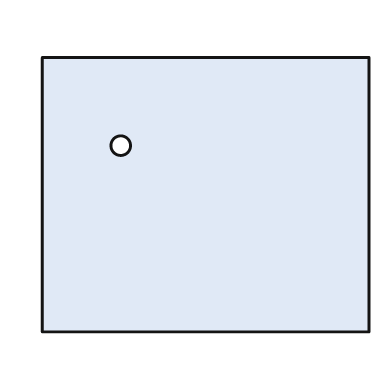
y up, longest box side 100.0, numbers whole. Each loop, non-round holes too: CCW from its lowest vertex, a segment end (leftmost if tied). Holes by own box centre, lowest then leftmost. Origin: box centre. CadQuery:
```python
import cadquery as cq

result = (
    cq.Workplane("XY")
    .moveTo(-50.0, -42.0)
    .lineTo(50.0, -42.0)
    .lineTo(50.0, 42.0)
    .lineTo(-50.0, 42.0)
    .close()
    .moveTo(-26.0, 15.0)
    .circle(3.0)
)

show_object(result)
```